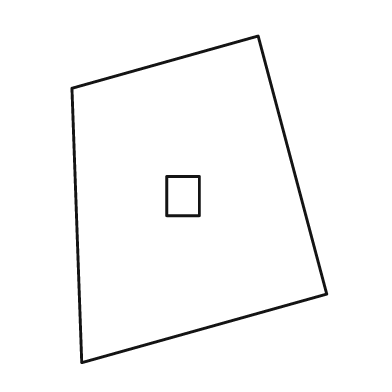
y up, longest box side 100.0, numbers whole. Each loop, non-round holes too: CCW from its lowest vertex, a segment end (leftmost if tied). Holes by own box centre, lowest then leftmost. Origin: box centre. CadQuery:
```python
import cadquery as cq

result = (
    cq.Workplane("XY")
    .moveTo(-36.0, -50.0)
    .lineTo(39.0, -29.0)
    .lineTo(18.0, 50.0)
    .lineTo(-39.0, 34.0)
    .close()
    .moveTo(-10.0, -5.0)
    .lineTo(0.0, -5.0)
    .lineTo(0.0, 7.0)
    .lineTo(-10.0, 7.0)
    .close()
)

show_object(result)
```